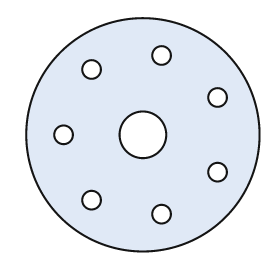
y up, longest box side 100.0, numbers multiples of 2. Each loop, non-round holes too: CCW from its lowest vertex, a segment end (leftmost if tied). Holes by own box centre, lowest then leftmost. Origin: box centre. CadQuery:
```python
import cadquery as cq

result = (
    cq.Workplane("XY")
    .moveTo(0.0, 0.0)
    .circle(50.0)
    .moveTo(8.0, -34.0)
    .circle(4.0)
    .moveTo(-22.0, -28.0)
    .circle(4.0)
    .moveTo(32.0, -16.0)
    .circle(4.0)
    .moveTo(-34.0, 0.0)
    .circle(4.0)
    .moveTo(0.0, 0.0)
    .circle(10.0)
    .moveTo(32.0, 16.0)
    .circle(4.0)
    .moveTo(-22.0, 28.0)
    .circle(4.0)
    .moveTo(8.0, 34.0)
    .circle(4.0)
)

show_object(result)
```